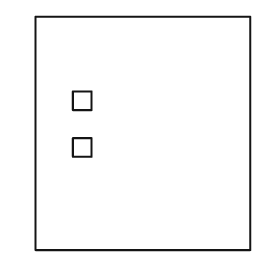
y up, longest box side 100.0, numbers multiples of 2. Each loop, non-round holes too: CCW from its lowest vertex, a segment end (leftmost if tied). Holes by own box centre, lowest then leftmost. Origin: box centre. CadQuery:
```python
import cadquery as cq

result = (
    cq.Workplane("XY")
    .moveTo(-46.0, -50.0)
    .lineTo(46.0, -50.0)
    .lineTo(46.0, 50.0)
    .lineTo(-46.0, 50.0)
    .close()
    .moveTo(-30.0, -10.0)
    .lineTo(-22.0, -10.0)
    .lineTo(-22.0, -2.0)
    .lineTo(-30.0, -2.0)
    .close()
    .moveTo(-30.0, 10.0)
    .lineTo(-22.0, 10.0)
    .lineTo(-22.0, 18.0)
    .lineTo(-30.0, 18.0)
    .close()
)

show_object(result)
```